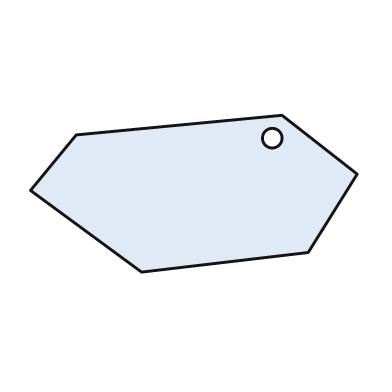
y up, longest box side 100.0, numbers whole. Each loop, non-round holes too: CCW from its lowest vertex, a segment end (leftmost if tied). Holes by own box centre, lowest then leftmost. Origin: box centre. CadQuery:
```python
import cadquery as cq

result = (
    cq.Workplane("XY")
    .moveTo(-16.0, -24.0)
    .lineTo(35.0, -18.0)
    .lineTo(50.0, 6.0)
    .lineTo(27.0, 24.0)
    .lineTo(-36.0, 18.0)
    .lineTo(-50.0, 1.0)
    .close()
    .moveTo(24.0, 17.0)
    .circle(3.0)
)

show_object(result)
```